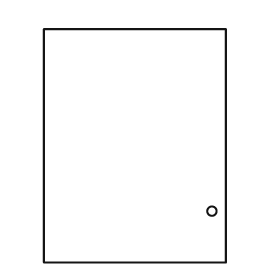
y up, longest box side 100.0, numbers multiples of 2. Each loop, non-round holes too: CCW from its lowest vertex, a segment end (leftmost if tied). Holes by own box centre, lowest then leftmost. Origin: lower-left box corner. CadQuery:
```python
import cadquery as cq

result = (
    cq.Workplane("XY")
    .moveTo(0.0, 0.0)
    .lineTo(78.0, 0.0)
    .lineTo(78.0, 100.0)
    .lineTo(0.0, 100.0)
    .close()
    .moveTo(72.0, 22.0)
    .circle(2.0)
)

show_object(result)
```